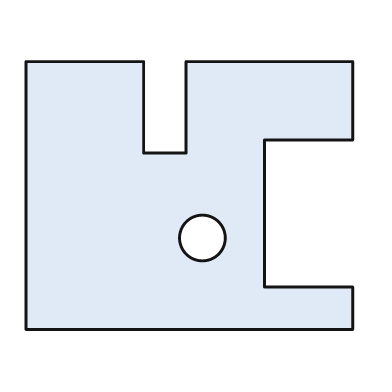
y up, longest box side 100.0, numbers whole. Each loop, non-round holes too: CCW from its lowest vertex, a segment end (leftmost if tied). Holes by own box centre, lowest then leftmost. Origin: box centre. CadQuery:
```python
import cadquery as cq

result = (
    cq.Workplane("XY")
    .moveTo(-50.0, -41.0)
    .lineTo(50.0, -41.0)
    .lineTo(50.0, -28.0)
    .lineTo(23.0, -28.0)
    .lineTo(23.0, 17.0)
    .lineTo(50.0, 17.0)
    .lineTo(50.0, 41.0)
    .lineTo(-1.0, 41.0)
    .lineTo(-1.0, 13.0)
    .lineTo(-14.0, 13.0)
    .lineTo(-14.0, 41.0)
    .lineTo(-50.0, 41.0)
    .close()
    .moveTo(4.0, -13.0)
    .circle(7.0)
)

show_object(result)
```